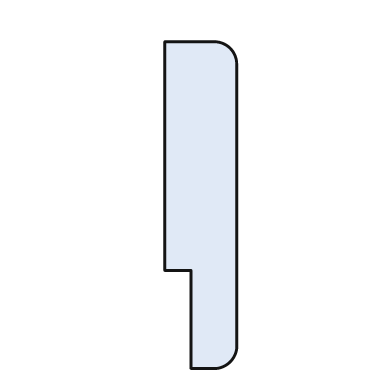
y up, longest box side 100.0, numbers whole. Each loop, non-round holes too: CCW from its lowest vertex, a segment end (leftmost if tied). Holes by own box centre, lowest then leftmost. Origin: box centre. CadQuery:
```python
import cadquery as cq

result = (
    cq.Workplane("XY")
    .moveTo(-3.0, -50.0)
    .lineTo(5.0, -50.0)
    .threePointArc((9.0, -48.0), (11.0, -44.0))
    .lineTo(11.0, 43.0)
    .threePointArc((9.0, 48.0), (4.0, 50.0))
    .lineTo(-11.0, 50.0)
    .lineTo(-11.0, -20.0)
    .lineTo(-3.0, -20.0)
    .close()
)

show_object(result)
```